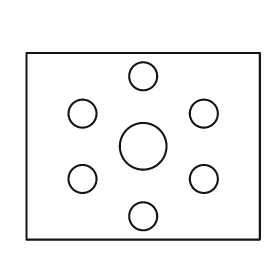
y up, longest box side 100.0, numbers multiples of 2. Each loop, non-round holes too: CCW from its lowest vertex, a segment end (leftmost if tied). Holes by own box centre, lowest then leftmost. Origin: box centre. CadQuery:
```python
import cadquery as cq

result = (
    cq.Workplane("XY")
    .moveTo(-50.0, -40.0)
    .lineTo(50.0, -40.0)
    .lineTo(50.0, 40.0)
    .lineTo(-50.0, 40.0)
    .close()
    .moveTo(0.0, -30.0)
    .circle(6.0)
    .moveTo(-26.0, -14.0)
    .circle(6.0)
    .moveTo(26.0, -14.0)
    .circle(6.0)
    .moveTo(0.0, 0.0)
    .circle(10.0)
    .moveTo(-26.0, 14.0)
    .circle(6.0)
    .moveTo(26.0, 14.0)
    .circle(6.0)
    .moveTo(0.0, 30.0)
    .circle(6.0)
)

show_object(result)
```